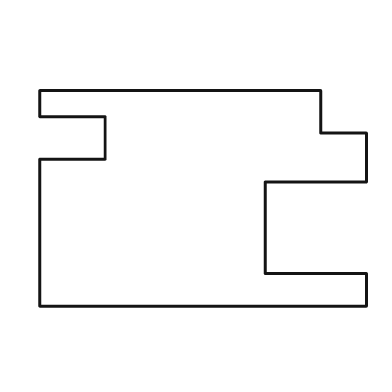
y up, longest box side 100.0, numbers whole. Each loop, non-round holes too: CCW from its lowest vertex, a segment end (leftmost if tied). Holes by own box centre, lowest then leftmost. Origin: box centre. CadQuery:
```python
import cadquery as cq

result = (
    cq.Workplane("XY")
    .moveTo(-50.0, -33.0)
    .lineTo(50.0, -33.0)
    .lineTo(50.0, -23.0)
    .lineTo(19.0, -23.0)
    .lineTo(19.0, 5.0)
    .lineTo(50.0, 5.0)
    .lineTo(50.0, 20.0)
    .lineTo(36.0, 20.0)
    .lineTo(36.0, 33.0)
    .lineTo(-50.0, 33.0)
    .lineTo(-50.0, 25.0)
    .lineTo(-30.0, 25.0)
    .lineTo(-30.0, 12.0)
    .lineTo(-50.0, 12.0)
    .close()
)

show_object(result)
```